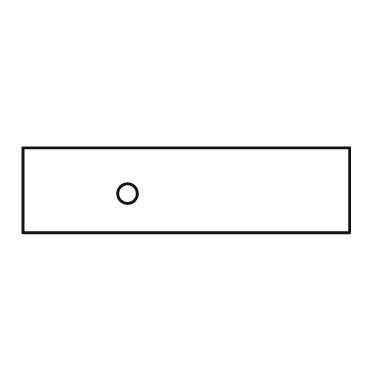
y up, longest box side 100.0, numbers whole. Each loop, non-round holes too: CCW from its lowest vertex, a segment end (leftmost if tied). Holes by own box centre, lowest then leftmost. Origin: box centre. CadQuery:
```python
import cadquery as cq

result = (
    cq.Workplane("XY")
    .moveTo(-50.0, -13.0)
    .lineTo(50.0, -13.0)
    .lineTo(50.0, 13.0)
    .lineTo(-50.0, 13.0)
    .close()
    .moveTo(-18.0, -1.0)
    .circle(3.0)
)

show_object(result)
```